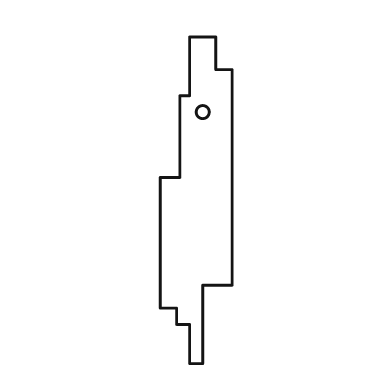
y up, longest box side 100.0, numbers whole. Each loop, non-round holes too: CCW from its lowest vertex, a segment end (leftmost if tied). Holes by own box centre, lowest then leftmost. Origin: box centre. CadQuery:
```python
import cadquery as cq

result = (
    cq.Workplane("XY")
    .moveTo(-2.0, -50.0)
    .lineTo(2.0, -50.0)
    .lineTo(2.0, -26.0)
    .lineTo(11.0, -26.0)
    .lineTo(11.0, 40.0)
    .lineTo(6.0, 40.0)
    .lineTo(6.0, 50.0)
    .lineTo(-2.0, 50.0)
    .lineTo(-2.0, 32.0)
    .lineTo(-5.0, 32.0)
    .lineTo(-5.0, 7.0)
    .lineTo(-11.0, 7.0)
    .lineTo(-11.0, -33.0)
    .lineTo(-6.0, -33.0)
    .lineTo(-6.0, -38.0)
    .lineTo(-2.0, -38.0)
    .close()
    .moveTo(2.0, 27.0)
    .circle(2.0)
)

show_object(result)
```